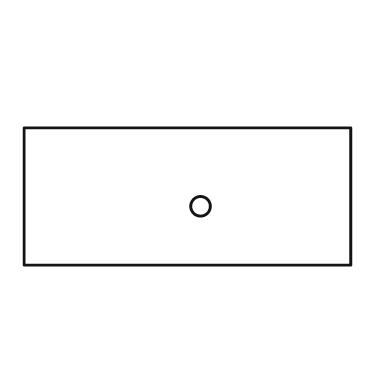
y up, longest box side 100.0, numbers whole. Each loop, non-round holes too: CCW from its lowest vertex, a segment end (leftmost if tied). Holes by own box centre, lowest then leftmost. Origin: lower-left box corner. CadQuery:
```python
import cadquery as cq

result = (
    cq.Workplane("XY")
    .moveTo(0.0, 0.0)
    .lineTo(100.0, 0.0)
    .lineTo(100.0, 42.0)
    .lineTo(0.0, 42.0)
    .close()
    .moveTo(54.0, 18.0)
    .circle(3.0)
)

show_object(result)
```